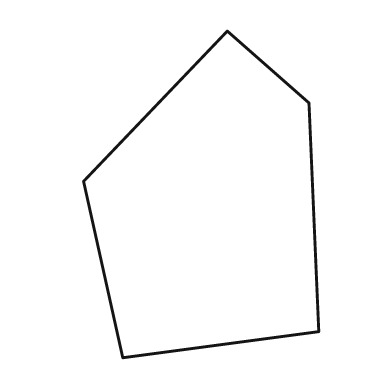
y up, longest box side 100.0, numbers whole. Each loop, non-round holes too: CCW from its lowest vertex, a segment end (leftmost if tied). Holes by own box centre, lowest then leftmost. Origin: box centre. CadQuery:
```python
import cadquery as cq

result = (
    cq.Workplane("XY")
    .moveTo(-24.0, -50.0)
    .lineTo(36.0, -42.0)
    .lineTo(33.0, 28.0)
    .lineTo(8.0, 50.0)
    .lineTo(-36.0, 4.0)
    .close()
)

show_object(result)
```